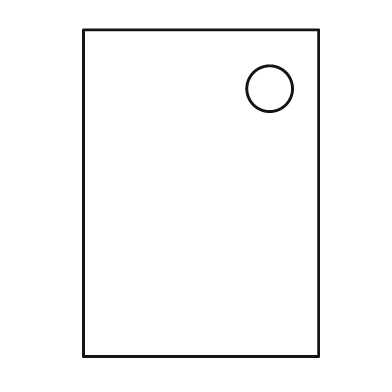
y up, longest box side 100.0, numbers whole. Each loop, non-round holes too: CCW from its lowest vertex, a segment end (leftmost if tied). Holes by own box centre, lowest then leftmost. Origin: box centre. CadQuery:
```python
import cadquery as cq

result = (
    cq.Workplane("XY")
    .moveTo(-36.0, -50.0)
    .lineTo(36.0, -50.0)
    .lineTo(36.0, 50.0)
    .lineTo(-36.0, 50.0)
    .close()
    .moveTo(21.0, 32.0)
    .circle(7.0)
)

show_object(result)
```